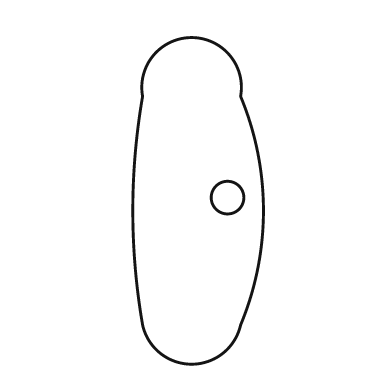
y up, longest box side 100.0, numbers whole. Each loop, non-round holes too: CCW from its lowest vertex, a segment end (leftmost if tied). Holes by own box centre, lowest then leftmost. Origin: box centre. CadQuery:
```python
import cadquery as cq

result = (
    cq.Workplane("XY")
    .moveTo(-17.0, -38.0)
    .threePointArc((-2.0, -50.0), (13.0, -38.0))
    .threePointArc((20.0, -3.0), (13.0, 32.0))
    .threePointArc((-2.0, 50.0), (-17.0, 32.0))
    .threePointArc((-20.0, -3.0), (-17.0, -38.0))
    .close()
    .moveTo(9.0, 1.0)
    .circle(5.0)
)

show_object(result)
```